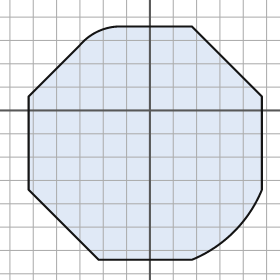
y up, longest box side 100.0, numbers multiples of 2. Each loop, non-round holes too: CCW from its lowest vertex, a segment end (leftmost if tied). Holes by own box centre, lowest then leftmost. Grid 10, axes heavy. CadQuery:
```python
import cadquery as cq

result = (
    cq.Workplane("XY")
    .moveTo(-22.0, -64.0)
    .lineTo(18.0, -64.0)
    .threePointArc((36.0, -52.0), (48.0, -34.0))
    .lineTo(48.0, 6.0)
    .lineTo(18.0, 36.0)
    .lineTo(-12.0, 36.0)
    .threePointArc((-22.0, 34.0), (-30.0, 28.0))
    .lineTo(-52.0, 6.0)
    .lineTo(-52.0, -34.0)
    .close()
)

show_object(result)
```